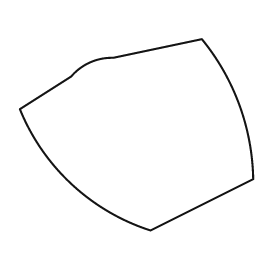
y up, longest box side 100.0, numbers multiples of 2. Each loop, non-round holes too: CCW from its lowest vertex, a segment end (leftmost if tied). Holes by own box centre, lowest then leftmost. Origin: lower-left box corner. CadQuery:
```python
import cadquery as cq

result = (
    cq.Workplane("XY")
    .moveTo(56.0, 0.0)
    .lineTo(100.0, 22.0)
    .threePointArc((94.0, 54.0), (78.0, 82.0))
    .lineTo(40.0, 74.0)
    .threePointArc((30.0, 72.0), (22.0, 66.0))
    .lineTo(0.0, 52.0)
    .threePointArc((22.0, 20.0), (56.0, 0.0))
    .close()
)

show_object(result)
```